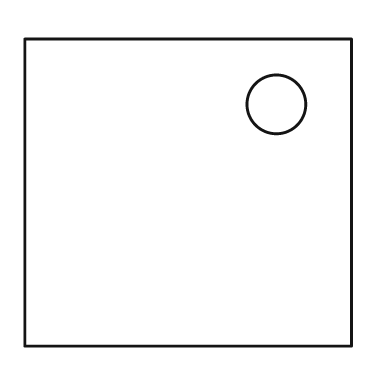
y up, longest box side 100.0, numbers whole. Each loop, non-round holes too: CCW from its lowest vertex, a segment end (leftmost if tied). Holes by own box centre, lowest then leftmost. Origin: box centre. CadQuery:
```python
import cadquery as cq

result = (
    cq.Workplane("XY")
    .moveTo(-50.0, -47.0)
    .lineTo(50.0, -47.0)
    .lineTo(50.0, 47.0)
    .lineTo(-50.0, 47.0)
    .close()
    .moveTo(27.0, 27.0)
    .circle(9.0)
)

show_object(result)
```